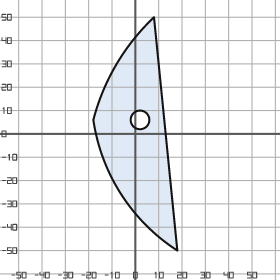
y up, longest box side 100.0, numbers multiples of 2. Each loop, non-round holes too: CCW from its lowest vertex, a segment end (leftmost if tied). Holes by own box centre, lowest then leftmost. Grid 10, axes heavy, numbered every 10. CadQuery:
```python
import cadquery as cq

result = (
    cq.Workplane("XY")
    .moveTo(18.0, -50.0)
    .lineTo(8.0, 50.0)
    .threePointArc((-8.0, 30.0), (-18.0, 6.0))
    .threePointArc((-6.0, -26.0), (18.0, -50.0))
    .close()
    .moveTo(2.0, 6.0)
    .circle(4.0)
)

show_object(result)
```